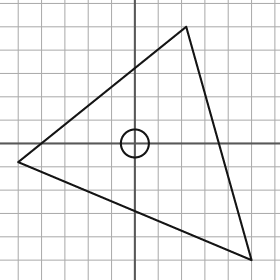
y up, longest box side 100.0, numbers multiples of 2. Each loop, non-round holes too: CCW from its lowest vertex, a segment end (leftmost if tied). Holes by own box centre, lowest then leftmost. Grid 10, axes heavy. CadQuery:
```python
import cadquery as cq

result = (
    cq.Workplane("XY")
    .moveTo(50.0, -50.0)
    .lineTo(22.0, 50.0)
    .lineTo(-50.0, -8.0)
    .close()
    .moveTo(0.0, 0.0)
    .circle(6.0)
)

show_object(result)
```